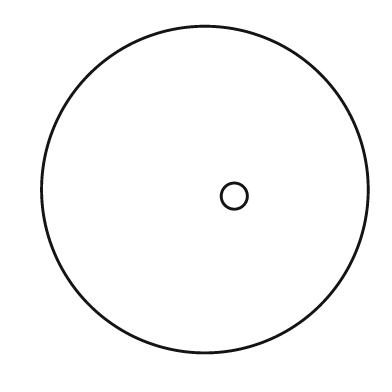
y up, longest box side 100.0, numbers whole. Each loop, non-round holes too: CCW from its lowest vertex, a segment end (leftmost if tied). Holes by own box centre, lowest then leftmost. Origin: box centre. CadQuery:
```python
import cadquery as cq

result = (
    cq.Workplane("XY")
    .moveTo(0.0, 0.0)
    .circle(50.0)
    .moveTo(9.0, -2.0)
    .circle(4.0)
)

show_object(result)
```